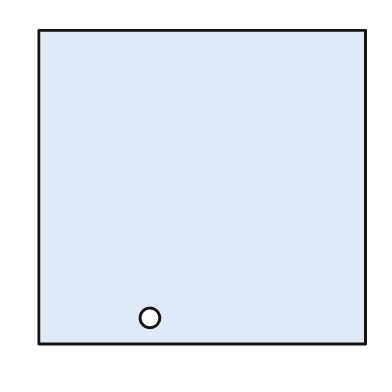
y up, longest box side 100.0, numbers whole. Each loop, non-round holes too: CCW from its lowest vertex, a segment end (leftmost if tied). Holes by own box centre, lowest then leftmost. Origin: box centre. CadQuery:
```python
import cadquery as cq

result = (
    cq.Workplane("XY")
    .moveTo(-50.0, -48.0)
    .lineTo(50.0, -48.0)
    .lineTo(50.0, 48.0)
    .lineTo(-50.0, 48.0)
    .close()
    .moveTo(-16.0, -40.0)
    .circle(3.0)
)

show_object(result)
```